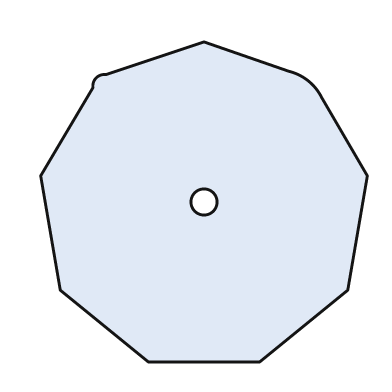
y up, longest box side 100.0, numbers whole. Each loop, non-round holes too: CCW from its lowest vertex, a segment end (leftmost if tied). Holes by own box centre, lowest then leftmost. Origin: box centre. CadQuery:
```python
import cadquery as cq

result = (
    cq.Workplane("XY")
    .moveTo(-17.0, -49.0)
    .lineTo(17.0, -49.0)
    .lineTo(44.0, -27.0)
    .lineTo(50.0, 8.0)
    .lineTo(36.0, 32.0)
    .threePointArc((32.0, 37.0), (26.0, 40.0))
    .lineTo(0.0, 49.0)
    .lineTo(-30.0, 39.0)
    .threePointArc((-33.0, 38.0), (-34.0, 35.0))
    .lineTo(-50.0, 8.0)
    .lineTo(-44.0, -27.0)
    .close()
    .moveTo(0.0, 0.0)
    .circle(4.0)
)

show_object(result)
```